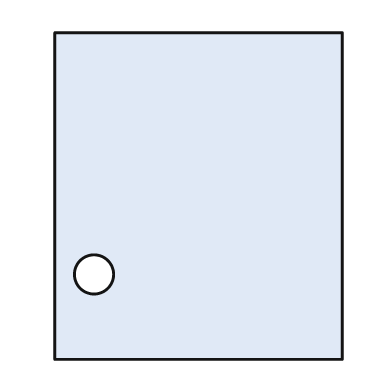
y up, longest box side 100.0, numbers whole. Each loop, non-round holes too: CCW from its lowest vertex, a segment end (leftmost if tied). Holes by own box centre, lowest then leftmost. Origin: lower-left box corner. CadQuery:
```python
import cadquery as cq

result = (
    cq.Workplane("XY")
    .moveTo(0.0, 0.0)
    .lineTo(88.0, 0.0)
    .lineTo(88.0, 100.0)
    .lineTo(0.0, 100.0)
    .close()
    .moveTo(12.0, 26.0)
    .circle(6.0)
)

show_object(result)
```